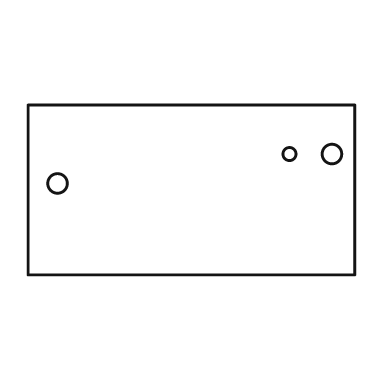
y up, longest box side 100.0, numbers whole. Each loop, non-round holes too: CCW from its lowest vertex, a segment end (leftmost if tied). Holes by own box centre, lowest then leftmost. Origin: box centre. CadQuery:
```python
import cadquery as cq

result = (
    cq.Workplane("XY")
    .moveTo(-50.0, -26.0)
    .lineTo(50.0, -26.0)
    .lineTo(50.0, 26.0)
    .lineTo(-50.0, 26.0)
    .close()
    .moveTo(-41.0, 2.0)
    .circle(3.0)
    .moveTo(30.0, 11.0)
    .circle(2.0)
    .moveTo(43.0, 11.0)
    .circle(3.0)
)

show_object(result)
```